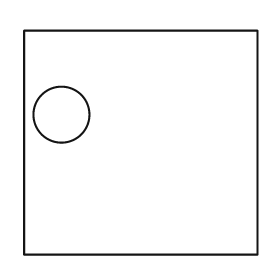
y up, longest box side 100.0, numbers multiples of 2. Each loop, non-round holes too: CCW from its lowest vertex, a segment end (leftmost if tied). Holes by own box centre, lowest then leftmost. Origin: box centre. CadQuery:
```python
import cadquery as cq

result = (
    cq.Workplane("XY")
    .moveTo(-50.0, -48.0)
    .lineTo(50.0, -48.0)
    .lineTo(50.0, 48.0)
    .lineTo(-50.0, 48.0)
    .close()
    .moveTo(-34.0, 12.0)
    .circle(12.0)
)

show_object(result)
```